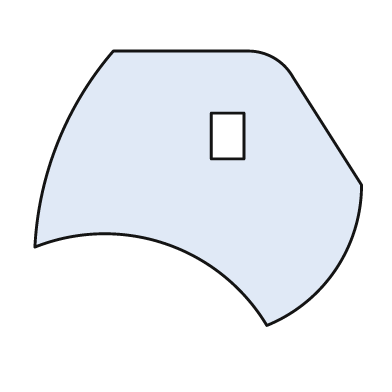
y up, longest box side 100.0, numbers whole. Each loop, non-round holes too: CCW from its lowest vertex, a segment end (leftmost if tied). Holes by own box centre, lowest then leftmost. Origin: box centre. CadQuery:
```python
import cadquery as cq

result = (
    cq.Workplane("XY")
    .moveTo(21.0, -42.0)
    .threePointArc((42.0, -25.0), (50.0, 1.0))
    .lineTo(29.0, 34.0)
    .threePointArc((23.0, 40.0), (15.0, 42.0))
    .lineTo(-26.0, 42.0)
    .threePointArc((-43.0, 14.0), (-50.0, -18.0))
    .threePointArc((-10.0, -17.0), (21.0, -42.0))
    .close()
    .moveTo(4.0, 9.0)
    .lineTo(14.0, 9.0)
    .lineTo(14.0, 23.0)
    .lineTo(4.0, 23.0)
    .close()
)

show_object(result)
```